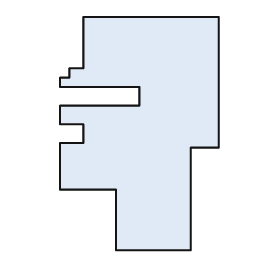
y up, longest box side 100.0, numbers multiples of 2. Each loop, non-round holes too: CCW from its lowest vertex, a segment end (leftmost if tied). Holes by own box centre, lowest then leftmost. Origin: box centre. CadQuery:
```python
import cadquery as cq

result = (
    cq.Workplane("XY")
    .moveTo(-10.0, -50.0)
    .lineTo(22.0, -50.0)
    .lineTo(22.0, -6.0)
    .lineTo(34.0, -6.0)
    .lineTo(34.0, 50.0)
    .lineTo(-24.0, 50.0)
    .lineTo(-24.0, 28.0)
    .lineTo(-30.0, 28.0)
    .lineTo(-30.0, 24.0)
    .lineTo(-34.0, 24.0)
    .lineTo(-34.0, 20.0)
    .lineTo(0.0, 20.0)
    .lineTo(0.0, 12.0)
    .lineTo(-34.0, 12.0)
    .lineTo(-34.0, 4.0)
    .lineTo(-24.0, 4.0)
    .lineTo(-24.0, -4.0)
    .lineTo(-34.0, -4.0)
    .lineTo(-34.0, -24.0)
    .lineTo(-10.0, -24.0)
    .close()
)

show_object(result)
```